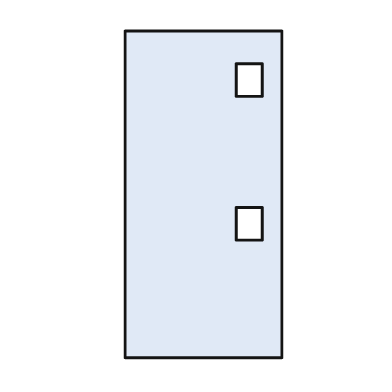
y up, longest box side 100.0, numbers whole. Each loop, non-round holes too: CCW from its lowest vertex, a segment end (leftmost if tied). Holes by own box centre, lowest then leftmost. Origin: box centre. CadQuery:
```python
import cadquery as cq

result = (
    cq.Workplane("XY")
    .moveTo(-24.0, -50.0)
    .lineTo(24.0, -50.0)
    .lineTo(24.0, 50.0)
    .lineTo(-24.0, 50.0)
    .close()
    .moveTo(10.0, -14.0)
    .lineTo(18.0, -14.0)
    .lineTo(18.0, -4.0)
    .lineTo(10.0, -4.0)
    .close()
    .moveTo(10.0, 30.0)
    .lineTo(18.0, 30.0)
    .lineTo(18.0, 40.0)
    .lineTo(10.0, 40.0)
    .close()
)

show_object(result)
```